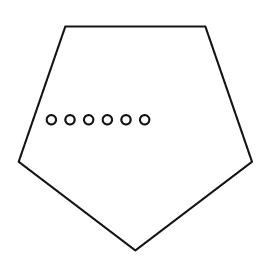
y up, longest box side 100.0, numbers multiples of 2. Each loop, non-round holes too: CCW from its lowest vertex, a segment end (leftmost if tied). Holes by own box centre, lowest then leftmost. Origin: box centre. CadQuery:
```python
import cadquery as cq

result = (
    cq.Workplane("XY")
    .moveTo(0.0, -48.0)
    .lineTo(50.0, -10.0)
    .lineTo(30.0, 48.0)
    .lineTo(-30.0, 48.0)
    .lineTo(-50.0, -10.0)
    .close()
    .moveTo(-36.0, 8.0)
    .circle(2.0)
    .moveTo(-28.0, 8.0)
    .circle(2.0)
    .moveTo(-20.0, 8.0)
    .circle(2.0)
    .moveTo(-12.0, 8.0)
    .circle(2.0)
    .moveTo(-4.0, 8.0)
    .circle(2.0)
    .moveTo(4.0, 8.0)
    .circle(2.0)
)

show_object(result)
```